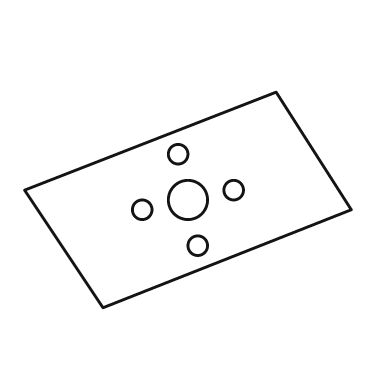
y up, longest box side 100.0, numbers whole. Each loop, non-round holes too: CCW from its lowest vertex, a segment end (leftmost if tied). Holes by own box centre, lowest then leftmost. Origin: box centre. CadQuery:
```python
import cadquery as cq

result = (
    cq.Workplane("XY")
    .moveTo(-26.0, -33.0)
    .lineTo(50.0, -3.0)
    .lineTo(27.0, 33.0)
    .lineTo(-50.0, 3.0)
    .close()
    .moveTo(3.0, -14.0)
    .circle(3.0)
    .moveTo(-14.0, -3.0)
    .circle(3.0)
    .moveTo(0.0, 0.0)
    .circle(6.0)
    .moveTo(14.0, 3.0)
    .circle(3.0)
    .moveTo(-3.0, 14.0)
    .circle(3.0)
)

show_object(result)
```